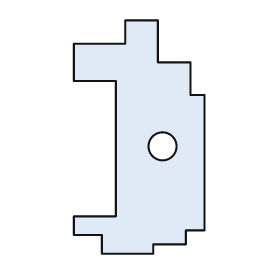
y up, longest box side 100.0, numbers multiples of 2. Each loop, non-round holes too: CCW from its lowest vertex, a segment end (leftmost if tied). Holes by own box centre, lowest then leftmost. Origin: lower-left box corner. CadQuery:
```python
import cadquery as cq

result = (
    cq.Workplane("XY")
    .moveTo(12.0, 0.0)
    .lineTo(34.0, 0.0)
    .lineTo(34.0, 4.0)
    .lineTo(48.0, 4.0)
    .lineTo(48.0, 10.0)
    .lineTo(56.0, 10.0)
    .lineTo(56.0, 68.0)
    .lineTo(50.0, 68.0)
    .lineTo(50.0, 82.0)
    .lineTo(36.0, 82.0)
    .lineTo(36.0, 100.0)
    .lineTo(22.0, 100.0)
    .lineTo(22.0, 90.0)
    .lineTo(0.0, 90.0)
    .lineTo(0.0, 74.0)
    .lineTo(18.0, 74.0)
    .lineTo(18.0, 16.0)
    .lineTo(0.0, 16.0)
    .lineTo(0.0, 8.0)
    .lineTo(12.0, 8.0)
    .close()
    .moveTo(38.0, 46.0)
    .circle(6.0)
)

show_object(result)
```